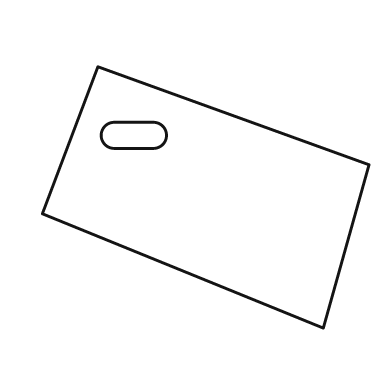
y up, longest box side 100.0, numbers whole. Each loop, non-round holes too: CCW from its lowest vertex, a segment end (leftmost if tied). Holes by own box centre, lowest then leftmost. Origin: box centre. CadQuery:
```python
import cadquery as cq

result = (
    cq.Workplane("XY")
    .moveTo(36.0, -40.0)
    .lineTo(50.0, 10.0)
    .lineTo(-33.0, 40.0)
    .lineTo(-50.0, -5.0)
    .close()
    .moveTo(-28.0, 15.0)
    .lineTo(-16.0, 15.0)
    .threePointArc((-12.0, 19.0), (-16.0, 23.0))
    .lineTo(-28.0, 23.0)
    .threePointArc((-32.0, 19.0), (-28.0, 15.0))
    .close()
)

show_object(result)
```